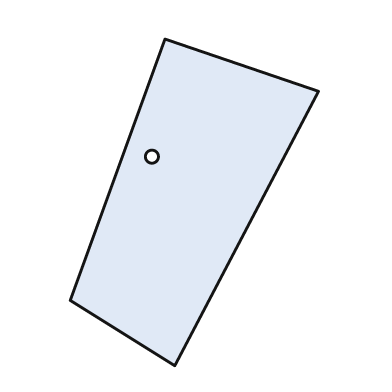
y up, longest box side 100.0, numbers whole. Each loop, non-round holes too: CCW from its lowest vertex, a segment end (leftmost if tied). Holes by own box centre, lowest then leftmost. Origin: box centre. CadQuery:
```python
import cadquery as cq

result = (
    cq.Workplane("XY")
    .moveTo(-6.0, -50.0)
    .lineTo(38.0, 34.0)
    .lineTo(-9.0, 50.0)
    .lineTo(-38.0, -30.0)
    .close()
    .moveTo(-13.0, 14.0)
    .circle(2.0)
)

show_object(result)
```